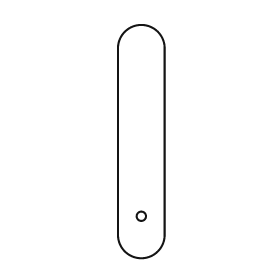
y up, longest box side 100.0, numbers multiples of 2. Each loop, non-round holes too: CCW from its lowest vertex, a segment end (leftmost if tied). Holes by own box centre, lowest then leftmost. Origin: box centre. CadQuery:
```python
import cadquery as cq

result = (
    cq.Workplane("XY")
    .moveTo(-10.0, -40.0)
    .threePointArc((0.0, -50.0), (10.0, -40.0))
    .lineTo(10.0, 40.0)
    .threePointArc((0.0, 50.0), (-10.0, 40.0))
    .close()
    .moveTo(0.0, -32.0)
    .circle(2.0)
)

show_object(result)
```